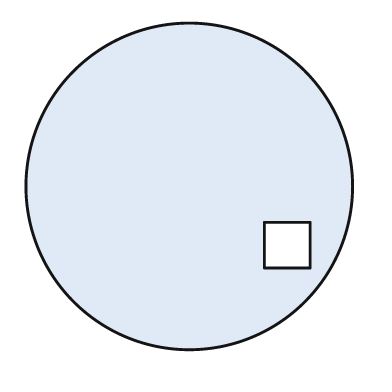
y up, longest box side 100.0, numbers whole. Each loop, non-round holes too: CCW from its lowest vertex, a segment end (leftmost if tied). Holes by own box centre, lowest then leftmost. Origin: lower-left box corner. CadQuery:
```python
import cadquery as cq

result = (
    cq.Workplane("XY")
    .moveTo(50.0, 50.0)
    .circle(50.0)
    .moveTo(73.0, 25.0)
    .lineTo(87.0, 25.0)
    .lineTo(87.0, 39.0)
    .lineTo(73.0, 39.0)
    .close()
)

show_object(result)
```